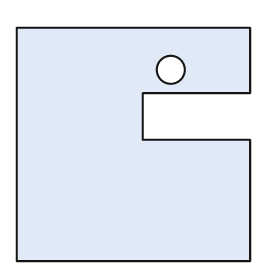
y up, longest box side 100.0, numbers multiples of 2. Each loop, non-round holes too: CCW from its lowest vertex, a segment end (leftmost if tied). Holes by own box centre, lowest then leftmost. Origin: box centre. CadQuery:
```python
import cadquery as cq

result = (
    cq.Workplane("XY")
    .moveTo(-50.0, -50.0)
    .lineTo(50.0, -50.0)
    .lineTo(50.0, 2.0)
    .lineTo(4.0, 2.0)
    .lineTo(4.0, 22.0)
    .lineTo(50.0, 22.0)
    .lineTo(50.0, 50.0)
    .lineTo(-50.0, 50.0)
    .close()
    .moveTo(16.0, 32.0)
    .circle(6.0)
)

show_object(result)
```